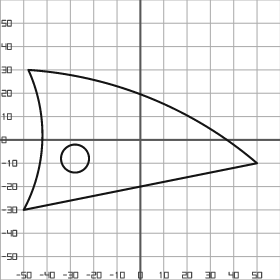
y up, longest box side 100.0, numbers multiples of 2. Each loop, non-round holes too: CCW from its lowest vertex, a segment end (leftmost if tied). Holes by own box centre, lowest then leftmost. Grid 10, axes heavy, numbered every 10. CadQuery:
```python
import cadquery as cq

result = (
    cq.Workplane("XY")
    .moveTo(-50.0, -30.0)
    .lineTo(50.0, -10.0)
    .threePointArc((4.0, 18.0), (-48.0, 30.0))
    .threePointArc((-42.0, 0.0), (-50.0, -30.0))
    .close()
    .moveTo(-28.0, -8.0)
    .circle(6.0)
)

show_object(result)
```